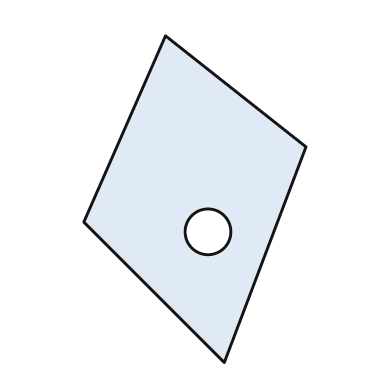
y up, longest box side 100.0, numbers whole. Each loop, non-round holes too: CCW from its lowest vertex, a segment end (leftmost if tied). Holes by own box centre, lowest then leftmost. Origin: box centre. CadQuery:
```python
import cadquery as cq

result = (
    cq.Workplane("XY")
    .moveTo(9.0, -50.0)
    .lineTo(34.0, 16.0)
    .lineTo(-9.0, 50.0)
    .lineTo(-34.0, -7.0)
    .close()
    .moveTo(4.0, -10.0)
    .circle(7.0)
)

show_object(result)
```